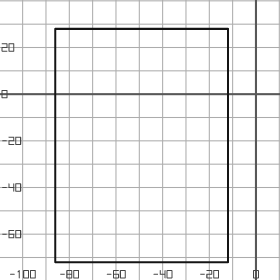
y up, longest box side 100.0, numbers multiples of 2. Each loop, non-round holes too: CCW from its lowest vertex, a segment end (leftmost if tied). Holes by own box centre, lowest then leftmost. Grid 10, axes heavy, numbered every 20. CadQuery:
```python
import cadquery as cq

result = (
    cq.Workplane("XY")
    .moveTo(-86.0, -72.0)
    .lineTo(-12.0, -72.0)
    .lineTo(-12.0, 28.0)
    .lineTo(-86.0, 28.0)
    .close()
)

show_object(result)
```